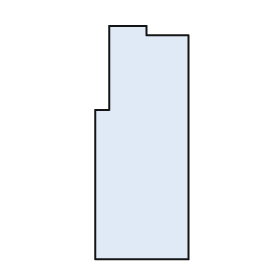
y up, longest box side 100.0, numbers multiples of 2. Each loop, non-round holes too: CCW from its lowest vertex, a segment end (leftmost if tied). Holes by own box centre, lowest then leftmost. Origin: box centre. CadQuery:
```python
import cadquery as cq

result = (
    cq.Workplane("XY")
    .moveTo(-20.0, -50.0)
    .lineTo(20.0, -50.0)
    .lineTo(20.0, 46.0)
    .lineTo(2.0, 46.0)
    .lineTo(2.0, 50.0)
    .lineTo(-14.0, 50.0)
    .lineTo(-14.0, 14.0)
    .lineTo(-20.0, 14.0)
    .close()
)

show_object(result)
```